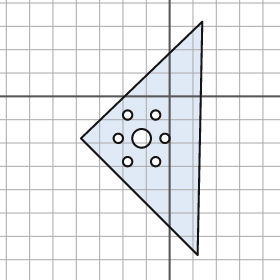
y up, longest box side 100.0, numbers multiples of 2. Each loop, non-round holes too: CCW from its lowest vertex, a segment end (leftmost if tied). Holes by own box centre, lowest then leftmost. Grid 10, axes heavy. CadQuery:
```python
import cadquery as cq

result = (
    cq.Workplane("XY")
    .moveTo(12.0, -68.0)
    .lineTo(14.0, 32.0)
    .lineTo(-38.0, -18.0)
    .close()
    .moveTo(-18.0, -28.0)
    .circle(2.0)
    .moveTo(-6.0, -28.0)
    .circle(2.0)
    .moveTo(-22.0, -18.0)
    .circle(2.0)
    .moveTo(-12.0, -18.0)
    .circle(4.0)
    .moveTo(-2.0, -18.0)
    .circle(2.0)
    .moveTo(-18.0, -8.0)
    .circle(2.0)
    .moveTo(-6.0, -8.0)
    .circle(2.0)
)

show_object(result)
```